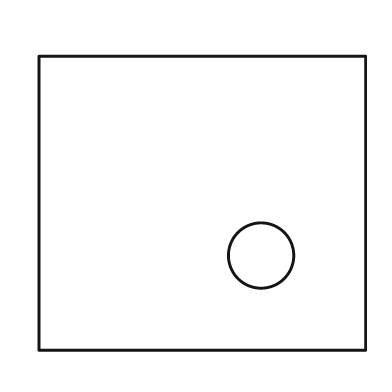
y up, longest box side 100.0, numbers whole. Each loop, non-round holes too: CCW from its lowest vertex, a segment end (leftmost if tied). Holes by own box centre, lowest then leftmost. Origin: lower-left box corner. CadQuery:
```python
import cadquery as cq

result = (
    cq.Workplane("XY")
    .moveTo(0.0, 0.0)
    .lineTo(100.0, 0.0)
    .lineTo(100.0, 90.0)
    .lineTo(0.0, 90.0)
    .close()
    .moveTo(68.0, 29.0)
    .circle(10.0)
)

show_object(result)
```